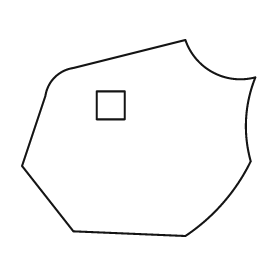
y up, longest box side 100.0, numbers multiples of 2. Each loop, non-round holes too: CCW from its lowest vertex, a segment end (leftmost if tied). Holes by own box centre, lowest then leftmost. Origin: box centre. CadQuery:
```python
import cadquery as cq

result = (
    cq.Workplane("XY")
    .moveTo(20.0, -42.0)
    .threePointArc((36.0, -28.0), (48.0, -10.0))
    .threePointArc((46.0, 8.0), (50.0, 26.0))
    .threePointArc((32.0, 28.0), (20.0, 42.0))
    .lineTo(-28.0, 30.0)
    .threePointArc((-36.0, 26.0), (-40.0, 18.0))
    .lineTo(-50.0, -12.0)
    .lineTo(-28.0, -40.0)
    .close()
    .moveTo(-18.0, 8.0)
    .lineTo(-6.0, 8.0)
    .lineTo(-6.0, 20.0)
    .lineTo(-18.0, 20.0)
    .close()
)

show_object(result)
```